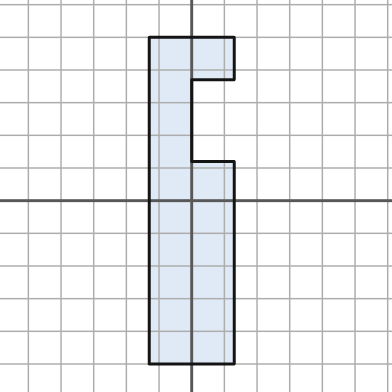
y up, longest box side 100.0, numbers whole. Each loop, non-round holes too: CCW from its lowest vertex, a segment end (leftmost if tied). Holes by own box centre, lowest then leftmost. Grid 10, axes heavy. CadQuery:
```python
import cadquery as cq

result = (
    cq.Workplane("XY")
    .moveTo(-13.0, -50.0)
    .lineTo(13.0, -50.0)
    .lineTo(13.0, 12.0)
    .lineTo(0.0, 12.0)
    .lineTo(0.0, 37.0)
    .lineTo(13.0, 37.0)
    .lineTo(13.0, 50.0)
    .lineTo(-13.0, 50.0)
    .close()
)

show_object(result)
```